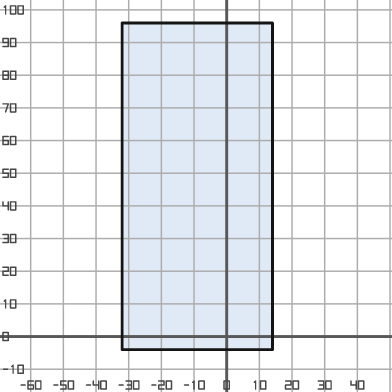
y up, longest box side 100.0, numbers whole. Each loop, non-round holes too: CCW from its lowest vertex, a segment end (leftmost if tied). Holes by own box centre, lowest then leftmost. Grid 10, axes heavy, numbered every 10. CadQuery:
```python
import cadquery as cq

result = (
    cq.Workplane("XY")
    .moveTo(-32.0, -4.0)
    .lineTo(14.0, -4.0)
    .lineTo(14.0, 96.0)
    .lineTo(-32.0, 96.0)
    .close()
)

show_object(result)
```